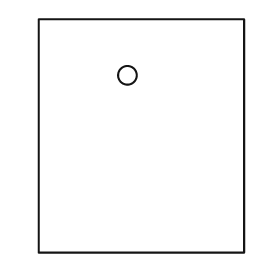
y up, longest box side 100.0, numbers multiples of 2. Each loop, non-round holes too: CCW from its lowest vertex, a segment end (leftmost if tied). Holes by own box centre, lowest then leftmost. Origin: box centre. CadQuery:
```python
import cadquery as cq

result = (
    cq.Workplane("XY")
    .moveTo(-44.0, -50.0)
    .lineTo(44.0, -50.0)
    .lineTo(44.0, 50.0)
    .lineTo(-44.0, 50.0)
    .close()
    .moveTo(-6.0, 26.0)
    .circle(4.0)
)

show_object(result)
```